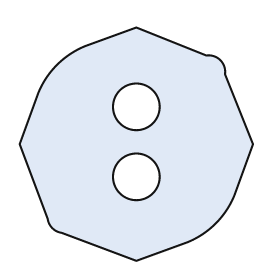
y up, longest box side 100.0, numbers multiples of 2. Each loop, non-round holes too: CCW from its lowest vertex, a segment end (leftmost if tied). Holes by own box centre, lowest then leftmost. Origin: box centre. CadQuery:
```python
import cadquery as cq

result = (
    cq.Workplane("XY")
    .moveTo(0.0, -50.0)
    .lineTo(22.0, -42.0)
    .threePointArc((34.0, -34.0), (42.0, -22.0))
    .lineTo(50.0, 0.0)
    .lineTo(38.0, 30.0)
    .threePointArc((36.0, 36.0), (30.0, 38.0))
    .lineTo(0.0, 50.0)
    .lineTo(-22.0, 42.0)
    .threePointArc((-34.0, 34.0), (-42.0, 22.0))
    .lineTo(-50.0, 0.0)
    .lineTo(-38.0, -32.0)
    .threePointArc((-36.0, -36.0), (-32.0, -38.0))
    .close()
    .moveTo(0.0, -14.0)
    .circle(10.0)
    .moveTo(0.0, 16.0)
    .circle(10.0)
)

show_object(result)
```